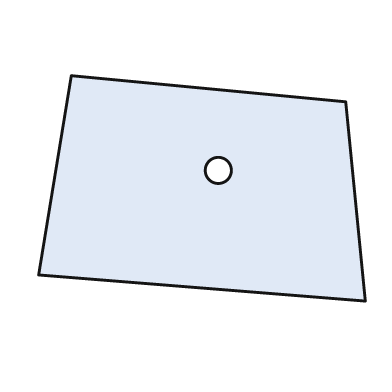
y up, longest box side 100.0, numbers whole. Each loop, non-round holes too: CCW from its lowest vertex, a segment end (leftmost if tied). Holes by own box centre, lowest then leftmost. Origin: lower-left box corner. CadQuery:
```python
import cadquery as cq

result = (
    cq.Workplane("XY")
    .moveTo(100.0, 0.0)
    .lineTo(94.0, 61.0)
    .lineTo(10.0, 69.0)
    .lineTo(0.0, 8.0)
    .close()
    .moveTo(55.0, 40.0)
    .circle(4.0)
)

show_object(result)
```